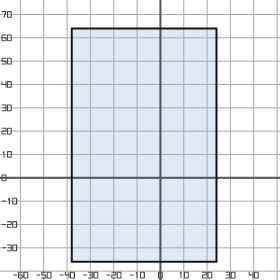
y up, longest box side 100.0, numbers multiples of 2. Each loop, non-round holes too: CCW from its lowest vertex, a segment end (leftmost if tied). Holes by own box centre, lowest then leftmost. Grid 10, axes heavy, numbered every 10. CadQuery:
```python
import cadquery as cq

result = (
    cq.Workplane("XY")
    .moveTo(-38.0, -36.0)
    .lineTo(24.0, -36.0)
    .lineTo(24.0, 64.0)
    .lineTo(-38.0, 64.0)
    .close()
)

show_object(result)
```